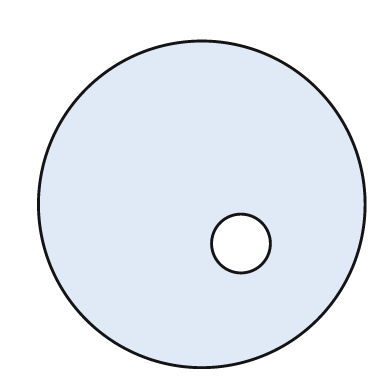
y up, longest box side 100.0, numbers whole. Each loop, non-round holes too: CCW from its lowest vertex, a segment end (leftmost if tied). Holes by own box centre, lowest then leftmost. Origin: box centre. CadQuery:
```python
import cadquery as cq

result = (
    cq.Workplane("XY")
    .moveTo(0.0, 0.0)
    .circle(50.0)
    .moveTo(12.0, -12.0)
    .circle(9.0)
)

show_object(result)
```